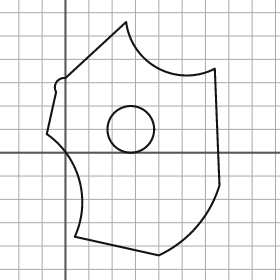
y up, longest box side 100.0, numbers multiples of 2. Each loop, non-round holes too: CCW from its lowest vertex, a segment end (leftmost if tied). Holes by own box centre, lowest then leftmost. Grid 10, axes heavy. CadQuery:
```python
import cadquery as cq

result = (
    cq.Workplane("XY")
    .moveTo(40.0, -44.0)
    .threePointArc((56.0, -32.0), (66.0, -14.0))
    .lineTo(64.0, 36.0)
    .threePointArc((40.0, 36.0), (26.0, 56.0))
    .lineTo(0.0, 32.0)
    .threePointArc((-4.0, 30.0), (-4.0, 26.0))
    .lineTo(-8.0, 8.0)
    .threePointArc((6.0, -12.0), (4.0, -36.0))
    .close()
    .moveTo(28.0, 10.0)
    .circle(10.0)
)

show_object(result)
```